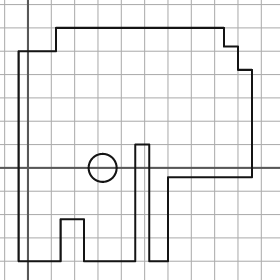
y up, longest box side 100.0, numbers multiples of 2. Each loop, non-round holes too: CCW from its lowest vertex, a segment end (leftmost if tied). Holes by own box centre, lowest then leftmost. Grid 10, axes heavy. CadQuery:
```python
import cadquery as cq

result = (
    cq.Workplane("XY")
    .moveTo(-4.0, -40.0)
    .lineTo(14.0, -40.0)
    .lineTo(14.0, -22.0)
    .lineTo(24.0, -22.0)
    .lineTo(24.0, -40.0)
    .lineTo(46.0, -40.0)
    .lineTo(46.0, 10.0)
    .lineTo(52.0, 10.0)
    .lineTo(52.0, -40.0)
    .lineTo(60.0, -40.0)
    .lineTo(60.0, -4.0)
    .lineTo(96.0, -4.0)
    .lineTo(96.0, 42.0)
    .lineTo(90.0, 42.0)
    .lineTo(90.0, 52.0)
    .lineTo(84.0, 52.0)
    .lineTo(84.0, 60.0)
    .lineTo(12.0, 60.0)
    .lineTo(12.0, 50.0)
    .lineTo(-4.0, 50.0)
    .close()
    .moveTo(32.0, 0.0)
    .circle(6.0)
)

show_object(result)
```